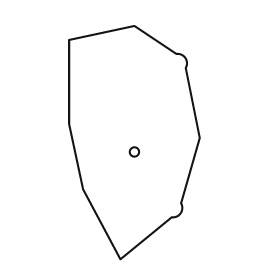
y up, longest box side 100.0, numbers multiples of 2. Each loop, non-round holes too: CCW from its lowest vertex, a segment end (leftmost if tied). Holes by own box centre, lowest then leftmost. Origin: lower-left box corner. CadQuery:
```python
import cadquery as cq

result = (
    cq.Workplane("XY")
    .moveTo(22.0, 0.0)
    .lineTo(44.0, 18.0)
    .threePointArc((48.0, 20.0), (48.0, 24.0))
    .lineTo(56.0, 52.0)
    .lineTo(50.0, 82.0)
    .threePointArc((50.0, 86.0), (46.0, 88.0))
    .lineTo(28.0, 100.0)
    .lineTo(0.0, 94.0)
    .lineTo(0.0, 58.0)
    .lineTo(6.0, 30.0)
    .close()
    .moveTo(28.0, 46.0)
    .circle(2.0)
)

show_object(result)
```